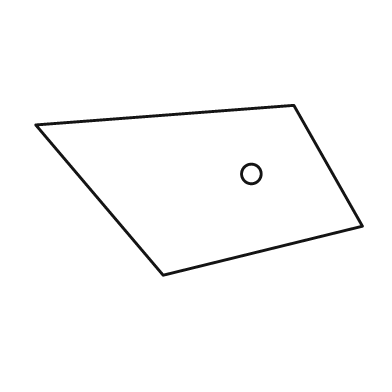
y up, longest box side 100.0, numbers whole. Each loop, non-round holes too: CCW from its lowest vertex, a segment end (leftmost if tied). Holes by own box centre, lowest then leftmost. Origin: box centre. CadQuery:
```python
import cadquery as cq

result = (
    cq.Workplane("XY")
    .moveTo(-11.0, -26.0)
    .lineTo(50.0, -11.0)
    .lineTo(29.0, 26.0)
    .lineTo(-50.0, 20.0)
    .close()
    .moveTo(16.0, 5.0)
    .circle(3.0)
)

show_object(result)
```